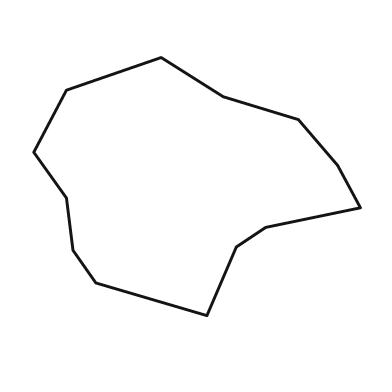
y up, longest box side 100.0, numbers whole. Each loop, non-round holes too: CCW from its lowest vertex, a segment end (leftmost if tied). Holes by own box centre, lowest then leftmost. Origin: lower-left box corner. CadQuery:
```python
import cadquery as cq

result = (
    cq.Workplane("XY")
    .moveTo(53.0, 0.0)
    .lineTo(62.0, 21.0)
    .lineTo(71.0, 27.0)
    .lineTo(100.0, 33.0)
    .lineTo(93.0, 46.0)
    .lineTo(81.0, 60.0)
    .lineTo(58.0, 67.0)
    .lineTo(39.0, 79.0)
    .lineTo(10.0, 69.0)
    .lineTo(0.0, 50.0)
    .lineTo(10.0, 36.0)
    .lineTo(12.0, 20.0)
    .lineTo(19.0, 10.0)
    .close()
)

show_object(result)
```